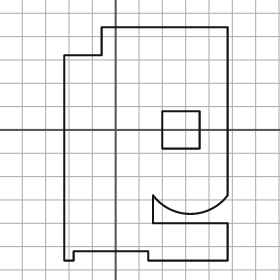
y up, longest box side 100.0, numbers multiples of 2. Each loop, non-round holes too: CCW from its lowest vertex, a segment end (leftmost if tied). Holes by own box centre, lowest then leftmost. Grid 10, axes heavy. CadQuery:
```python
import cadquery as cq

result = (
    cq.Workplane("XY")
    .moveTo(-22.0, -56.0)
    .lineTo(-18.0, -56.0)
    .lineTo(-18.0, -52.0)
    .lineTo(14.0, -52.0)
    .lineTo(14.0, -56.0)
    .lineTo(48.0, -56.0)
    .lineTo(48.0, -40.0)
    .lineTo(16.0, -40.0)
    .lineTo(16.0, -28.0)
    .threePointArc((32.0, -36.0), (48.0, -28.0))
    .lineTo(48.0, 44.0)
    .lineTo(-6.0, 44.0)
    .lineTo(-6.0, 32.0)
    .lineTo(-22.0, 32.0)
    .close()
    .moveTo(20.0, -8.0)
    .lineTo(36.0, -8.0)
    .lineTo(36.0, 8.0)
    .lineTo(20.0, 8.0)
    .close()
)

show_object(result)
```